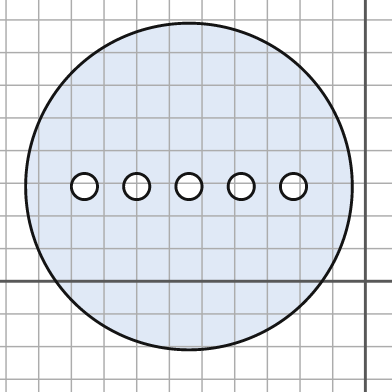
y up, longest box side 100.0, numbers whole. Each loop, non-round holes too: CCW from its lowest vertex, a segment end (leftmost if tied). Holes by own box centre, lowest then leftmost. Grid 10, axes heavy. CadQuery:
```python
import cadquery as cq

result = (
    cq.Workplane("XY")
    .moveTo(-54.0, 29.0)
    .circle(50.0)
    .moveTo(-86.0, 29.0)
    .circle(4.0)
    .moveTo(-70.0, 29.0)
    .circle(4.0)
    .moveTo(-54.0, 29.0)
    .circle(4.0)
    .moveTo(-38.0, 29.0)
    .circle(4.0)
    .moveTo(-22.0, 29.0)
    .circle(4.0)
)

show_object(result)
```